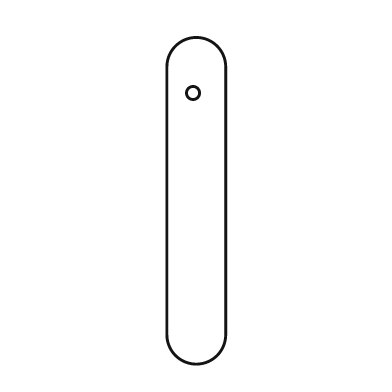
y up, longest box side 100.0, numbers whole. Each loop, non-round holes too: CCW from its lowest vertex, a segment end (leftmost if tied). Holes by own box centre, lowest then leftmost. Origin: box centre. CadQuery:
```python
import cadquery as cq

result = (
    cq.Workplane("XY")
    .moveTo(-9.0, -41.0)
    .threePointArc((0.0, -50.0), (9.0, -41.0))
    .lineTo(9.0, 41.0)
    .threePointArc((0.0, 50.0), (-9.0, 41.0))
    .close()
    .moveTo(-1.0, 33.0)
    .circle(2.0)
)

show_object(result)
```